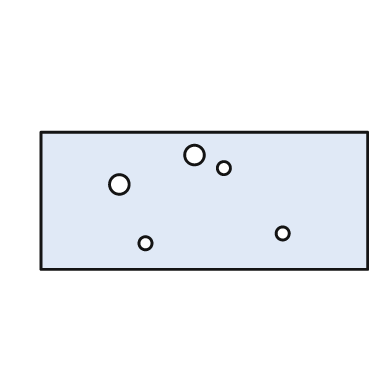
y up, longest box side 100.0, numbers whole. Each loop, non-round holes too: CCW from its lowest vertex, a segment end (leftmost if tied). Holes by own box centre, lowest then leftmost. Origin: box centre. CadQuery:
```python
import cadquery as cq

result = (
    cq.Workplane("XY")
    .moveTo(-50.0, -21.0)
    .lineTo(50.0, -21.0)
    .lineTo(50.0, 21.0)
    .lineTo(-50.0, 21.0)
    .close()
    .moveTo(-18.0, -13.0)
    .circle(2.0)
    .moveTo(24.0, -10.0)
    .circle(2.0)
    .moveTo(-26.0, 5.0)
    .circle(3.0)
    .moveTo(6.0, 10.0)
    .circle(2.0)
    .moveTo(-3.0, 14.0)
    .circle(3.0)
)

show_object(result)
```